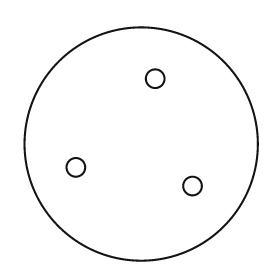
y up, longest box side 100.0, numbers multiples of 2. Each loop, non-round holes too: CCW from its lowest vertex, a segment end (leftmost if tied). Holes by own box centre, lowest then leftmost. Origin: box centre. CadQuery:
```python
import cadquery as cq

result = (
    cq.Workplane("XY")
    .moveTo(0.0, 0.0)
    .circle(50.0)
    .moveTo(22.0, -18.0)
    .circle(4.0)
    .moveTo(-28.0, -10.0)
    .circle(4.0)
    .moveTo(6.0, 28.0)
    .circle(4.0)
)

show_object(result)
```